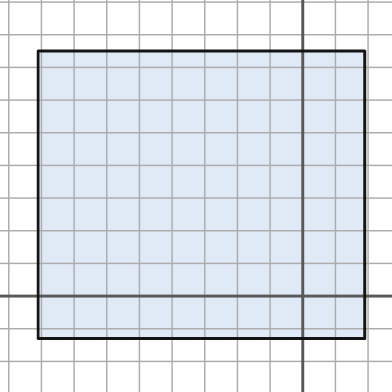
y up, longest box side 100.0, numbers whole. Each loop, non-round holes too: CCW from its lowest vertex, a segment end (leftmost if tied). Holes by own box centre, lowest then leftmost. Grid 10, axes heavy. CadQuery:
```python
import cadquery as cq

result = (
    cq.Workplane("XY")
    .moveTo(-81.0, -13.0)
    .lineTo(19.0, -13.0)
    .lineTo(19.0, 75.0)
    .lineTo(-81.0, 75.0)
    .close()
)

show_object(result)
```